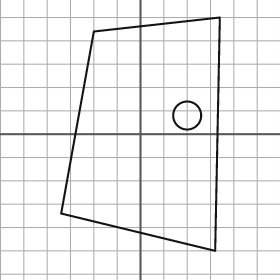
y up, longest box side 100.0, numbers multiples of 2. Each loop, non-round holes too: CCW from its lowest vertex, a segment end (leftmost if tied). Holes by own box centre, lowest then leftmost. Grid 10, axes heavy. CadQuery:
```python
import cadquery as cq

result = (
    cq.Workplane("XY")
    .moveTo(32.0, -50.0)
    .lineTo(34.0, 50.0)
    .lineTo(-20.0, 44.0)
    .lineTo(-34.0, -34.0)
    .close()
    .moveTo(20.0, 8.0)
    .circle(6.0)
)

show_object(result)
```